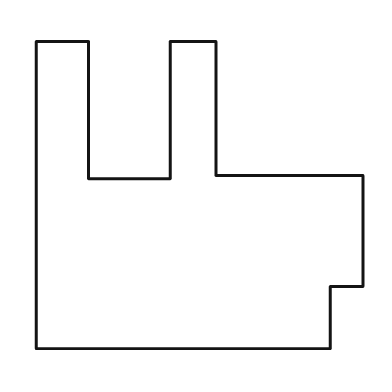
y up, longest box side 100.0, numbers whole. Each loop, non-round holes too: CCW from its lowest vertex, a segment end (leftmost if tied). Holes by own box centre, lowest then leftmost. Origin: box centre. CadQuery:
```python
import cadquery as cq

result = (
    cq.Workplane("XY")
    .moveTo(-50.0, -47.0)
    .lineTo(40.0, -47.0)
    .lineTo(40.0, -28.0)
    .lineTo(50.0, -28.0)
    .lineTo(50.0, 6.0)
    .lineTo(5.0, 6.0)
    .lineTo(5.0, 47.0)
    .lineTo(-9.0, 47.0)
    .lineTo(-9.0, 5.0)
    .lineTo(-34.0, 5.0)
    .lineTo(-34.0, 47.0)
    .lineTo(-50.0, 47.0)
    .close()
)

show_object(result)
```